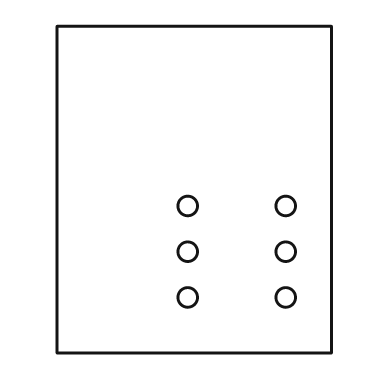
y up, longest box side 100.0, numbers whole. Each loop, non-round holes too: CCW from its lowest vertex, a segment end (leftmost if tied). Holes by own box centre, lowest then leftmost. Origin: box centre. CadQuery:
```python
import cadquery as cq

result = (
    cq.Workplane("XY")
    .moveTo(-42.0, -50.0)
    .lineTo(42.0, -50.0)
    .lineTo(42.0, 50.0)
    .lineTo(-42.0, 50.0)
    .close()
    .moveTo(-2.0, -33.0)
    .circle(3.0)
    .moveTo(28.0, -33.0)
    .circle(3.0)
    .moveTo(-2.0, -19.0)
    .circle(3.0)
    .moveTo(28.0, -19.0)
    .circle(3.0)
    .moveTo(-2.0, -5.0)
    .circle(3.0)
    .moveTo(28.0, -5.0)
    .circle(3.0)
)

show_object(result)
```